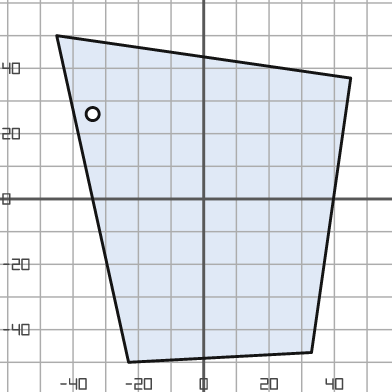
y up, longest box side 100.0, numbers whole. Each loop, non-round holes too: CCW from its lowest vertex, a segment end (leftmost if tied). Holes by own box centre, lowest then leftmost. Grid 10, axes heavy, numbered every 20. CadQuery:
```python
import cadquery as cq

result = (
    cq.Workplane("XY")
    .moveTo(-23.0, -50.0)
    .lineTo(33.0, -47.0)
    .lineTo(45.0, 37.0)
    .lineTo(-45.0, 50.0)
    .close()
    .moveTo(-34.0, 26.0)
    .circle(2.0)
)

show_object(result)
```